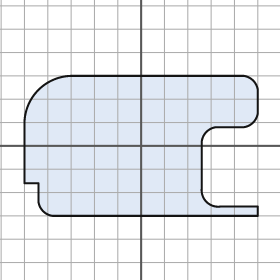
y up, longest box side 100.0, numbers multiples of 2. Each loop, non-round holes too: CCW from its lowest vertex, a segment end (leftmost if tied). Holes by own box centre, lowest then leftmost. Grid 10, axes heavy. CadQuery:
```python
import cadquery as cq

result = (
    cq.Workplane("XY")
    .moveTo(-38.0, -30.0)
    .lineTo(50.0, -30.0)
    .lineTo(50.0, -26.0)
    .lineTo(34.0, -26.0)
    .threePointArc((28.0, -24.0), (26.0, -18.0))
    .lineTo(26.0, 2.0)
    .threePointArc((28.0, 6.0), (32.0, 8.0))
    .lineTo(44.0, 8.0)
    .threePointArc((48.0, 10.0), (50.0, 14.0))
    .lineTo(50.0, 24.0)
    .threePointArc((48.0, 28.0), (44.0, 30.0))
    .lineTo(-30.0, 30.0)
    .threePointArc((-44.0, 24.0), (-50.0, 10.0))
    .lineTo(-50.0, -16.0)
    .lineTo(-44.0, -16.0)
    .lineTo(-44.0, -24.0)
    .threePointArc((-42.0, -28.0), (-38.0, -30.0))
    .close()
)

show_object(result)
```